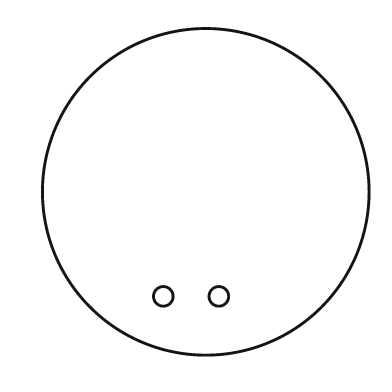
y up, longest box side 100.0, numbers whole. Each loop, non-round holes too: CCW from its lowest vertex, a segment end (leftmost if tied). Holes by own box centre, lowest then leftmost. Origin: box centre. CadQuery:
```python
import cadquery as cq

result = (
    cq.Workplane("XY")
    .moveTo(0.0, 0.0)
    .circle(50.0)
    .moveTo(-13.0, -32.0)
    .circle(3.0)
    .moveTo(4.0, -32.0)
    .circle(3.0)
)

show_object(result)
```